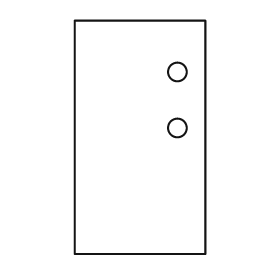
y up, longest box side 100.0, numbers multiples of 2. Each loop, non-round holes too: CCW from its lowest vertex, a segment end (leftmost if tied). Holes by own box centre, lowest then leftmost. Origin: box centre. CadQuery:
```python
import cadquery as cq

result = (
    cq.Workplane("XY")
    .moveTo(-28.0, -50.0)
    .lineTo(28.0, -50.0)
    .lineTo(28.0, 50.0)
    .lineTo(-28.0, 50.0)
    .close()
    .moveTo(16.0, 4.0)
    .circle(4.0)
    .moveTo(16.0, 28.0)
    .circle(4.0)
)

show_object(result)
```